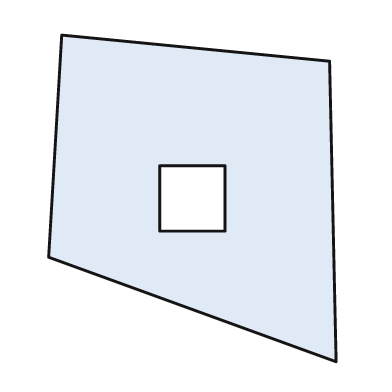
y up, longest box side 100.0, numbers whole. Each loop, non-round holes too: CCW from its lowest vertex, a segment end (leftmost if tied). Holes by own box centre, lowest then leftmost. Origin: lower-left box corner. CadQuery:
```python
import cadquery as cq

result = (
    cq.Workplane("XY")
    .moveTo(88.0, 0.0)
    .lineTo(86.0, 92.0)
    .lineTo(4.0, 100.0)
    .lineTo(0.0, 32.0)
    .close()
    .moveTo(34.0, 40.0)
    .lineTo(54.0, 40.0)
    .lineTo(54.0, 60.0)
    .lineTo(34.0, 60.0)
    .close()
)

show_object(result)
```